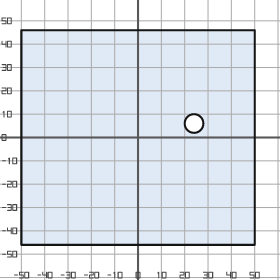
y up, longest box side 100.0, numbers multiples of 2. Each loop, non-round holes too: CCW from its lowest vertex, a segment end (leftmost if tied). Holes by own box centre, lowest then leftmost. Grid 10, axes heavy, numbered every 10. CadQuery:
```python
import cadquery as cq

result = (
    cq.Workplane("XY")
    .moveTo(-50.0, -46.0)
    .lineTo(50.0, -46.0)
    .lineTo(50.0, 46.0)
    .lineTo(-50.0, 46.0)
    .close()
    .moveTo(24.0, 6.0)
    .circle(4.0)
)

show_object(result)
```